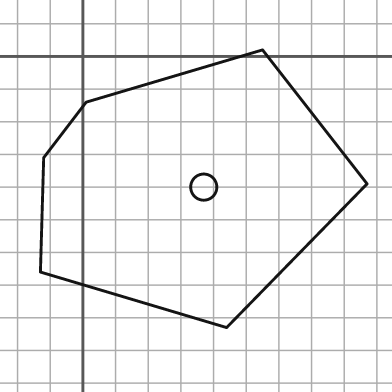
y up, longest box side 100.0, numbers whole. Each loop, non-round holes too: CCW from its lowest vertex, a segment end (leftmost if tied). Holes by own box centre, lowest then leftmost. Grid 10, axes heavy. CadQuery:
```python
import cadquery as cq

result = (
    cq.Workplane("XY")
    .moveTo(44.0, -83.0)
    .lineTo(87.0, -39.0)
    .lineTo(55.0, 2.0)
    .lineTo(1.0, -14.0)
    .lineTo(-12.0, -31.0)
    .lineTo(-13.0, -66.0)
    .close()
    .moveTo(37.0, -40.0)
    .circle(4.0)
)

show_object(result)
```